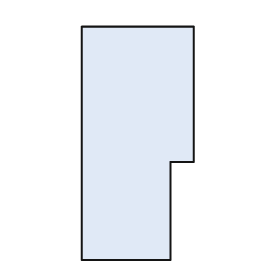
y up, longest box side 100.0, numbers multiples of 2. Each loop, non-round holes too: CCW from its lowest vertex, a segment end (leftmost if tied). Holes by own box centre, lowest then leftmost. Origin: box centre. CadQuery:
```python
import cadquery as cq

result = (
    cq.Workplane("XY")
    .moveTo(-24.0, -50.0)
    .lineTo(14.0, -50.0)
    .lineTo(14.0, -8.0)
    .lineTo(24.0, -8.0)
    .lineTo(24.0, 50.0)
    .lineTo(-24.0, 50.0)
    .close()
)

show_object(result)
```